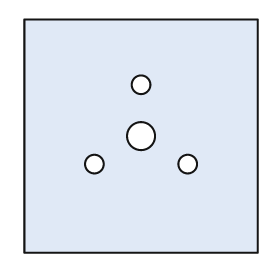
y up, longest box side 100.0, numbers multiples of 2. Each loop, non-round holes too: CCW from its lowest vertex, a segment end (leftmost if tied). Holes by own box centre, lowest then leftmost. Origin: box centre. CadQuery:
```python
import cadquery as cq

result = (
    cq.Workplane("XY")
    .moveTo(-50.0, -50.0)
    .lineTo(50.0, -50.0)
    .lineTo(50.0, 50.0)
    .lineTo(-50.0, 50.0)
    .close()
    .moveTo(-20.0, -12.0)
    .circle(4.0)
    .moveTo(20.0, -12.0)
    .circle(4.0)
    .moveTo(0.0, 0.0)
    .circle(6.0)
    .moveTo(0.0, 22.0)
    .circle(4.0)
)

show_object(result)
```